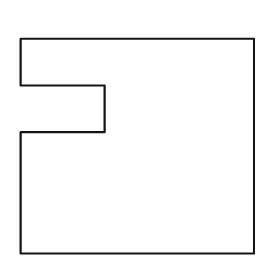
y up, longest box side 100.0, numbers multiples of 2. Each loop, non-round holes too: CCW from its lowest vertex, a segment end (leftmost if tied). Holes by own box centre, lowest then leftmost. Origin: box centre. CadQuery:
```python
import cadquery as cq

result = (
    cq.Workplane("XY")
    .moveTo(-50.0, -46.0)
    .lineTo(50.0, -46.0)
    .lineTo(50.0, 46.0)
    .lineTo(-50.0, 46.0)
    .lineTo(-50.0, 26.0)
    .lineTo(-14.0, 26.0)
    .lineTo(-14.0, 6.0)
    .lineTo(-50.0, 6.0)
    .close()
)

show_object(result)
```